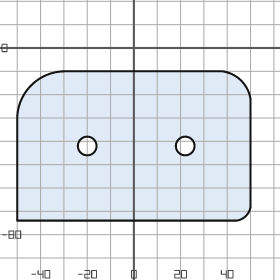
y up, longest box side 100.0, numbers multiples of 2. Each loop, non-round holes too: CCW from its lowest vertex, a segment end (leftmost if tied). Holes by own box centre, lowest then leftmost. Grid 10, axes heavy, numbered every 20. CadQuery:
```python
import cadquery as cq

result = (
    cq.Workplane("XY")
    .moveTo(-50.0, -74.0)
    .lineTo(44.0, -74.0)
    .threePointArc((48.0, -72.0), (50.0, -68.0))
    .lineTo(50.0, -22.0)
    .threePointArc((46.0, -14.0), (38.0, -10.0))
    .lineTo(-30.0, -10.0)
    .threePointArc((-44.0, -16.0), (-50.0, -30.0))
    .close()
    .moveTo(-20.0, -42.0)
    .circle(4.0)
    .moveTo(22.0, -42.0)
    .circle(4.0)
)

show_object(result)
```